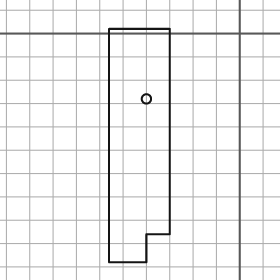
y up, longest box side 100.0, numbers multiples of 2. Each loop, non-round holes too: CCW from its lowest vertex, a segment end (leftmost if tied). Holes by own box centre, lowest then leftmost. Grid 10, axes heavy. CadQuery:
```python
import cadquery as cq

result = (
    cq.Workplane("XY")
    .moveTo(-56.0, -98.0)
    .lineTo(-40.0, -98.0)
    .lineTo(-40.0, -86.0)
    .lineTo(-30.0, -86.0)
    .lineTo(-30.0, 2.0)
    .lineTo(-56.0, 2.0)
    .close()
    .moveTo(-40.0, -28.0)
    .circle(2.0)
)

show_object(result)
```